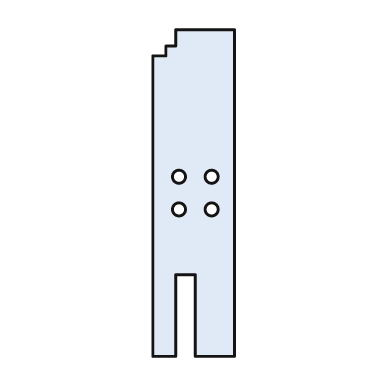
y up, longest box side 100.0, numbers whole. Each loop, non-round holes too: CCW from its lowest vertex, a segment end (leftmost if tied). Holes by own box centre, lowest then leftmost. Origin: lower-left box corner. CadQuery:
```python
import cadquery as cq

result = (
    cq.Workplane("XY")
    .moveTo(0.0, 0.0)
    .lineTo(7.0, 0.0)
    .lineTo(7.0, 25.0)
    .lineTo(13.0, 25.0)
    .lineTo(13.0, 0.0)
    .lineTo(25.0, 0.0)
    .lineTo(25.0, 100.0)
    .lineTo(7.0, 100.0)
    .lineTo(7.0, 95.0)
    .lineTo(4.0, 95.0)
    .lineTo(4.0, 92.0)
    .lineTo(0.0, 92.0)
    .close()
    .moveTo(8.0, 45.0)
    .circle(2.0)
    .moveTo(18.0, 45.0)
    .circle(2.0)
    .moveTo(8.0, 55.0)
    .circle(2.0)
    .moveTo(18.0, 55.0)
    .circle(2.0)
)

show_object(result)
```